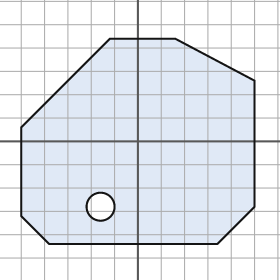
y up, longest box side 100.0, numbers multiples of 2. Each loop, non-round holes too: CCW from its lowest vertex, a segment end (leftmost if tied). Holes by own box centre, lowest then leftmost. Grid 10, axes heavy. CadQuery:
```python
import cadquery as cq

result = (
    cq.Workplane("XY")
    .moveTo(-38.0, -44.0)
    .lineTo(34.0, -44.0)
    .lineTo(50.0, -28.0)
    .lineTo(50.0, 26.0)
    .lineTo(16.0, 44.0)
    .lineTo(-12.0, 44.0)
    .lineTo(-50.0, 6.0)
    .lineTo(-50.0, -32.0)
    .close()
    .moveTo(-16.0, -28.0)
    .circle(6.0)
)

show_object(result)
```